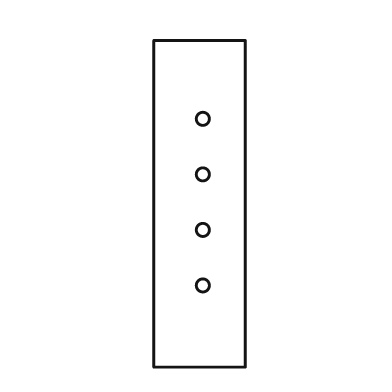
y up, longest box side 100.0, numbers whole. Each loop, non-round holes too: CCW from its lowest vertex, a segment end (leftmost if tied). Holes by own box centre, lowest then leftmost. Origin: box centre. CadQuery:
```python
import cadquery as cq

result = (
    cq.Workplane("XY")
    .moveTo(-14.0, -50.0)
    .lineTo(14.0, -50.0)
    .lineTo(14.0, 50.0)
    .lineTo(-14.0, 50.0)
    .close()
    .moveTo(1.0, -25.0)
    .circle(2.0)
    .moveTo(1.0, -8.0)
    .circle(2.0)
    .moveTo(1.0, 9.0)
    .circle(2.0)
    .moveTo(1.0, 26.0)
    .circle(2.0)
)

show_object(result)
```